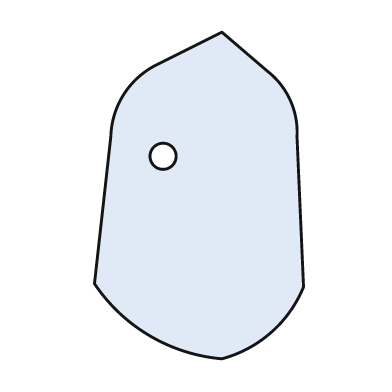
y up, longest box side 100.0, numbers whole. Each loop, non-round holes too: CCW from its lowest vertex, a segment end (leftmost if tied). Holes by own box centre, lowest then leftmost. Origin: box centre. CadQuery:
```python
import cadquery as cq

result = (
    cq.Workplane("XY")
    .moveTo(7.0, -50.0)
    .threePointArc((22.0, -42.0), (32.0, -28.0))
    .lineTo(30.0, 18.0)
    .threePointArc((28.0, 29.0), (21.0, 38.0))
    .lineTo(7.0, 50.0)
    .lineTo(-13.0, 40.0)
    .threePointArc((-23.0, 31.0), (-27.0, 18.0))
    .lineTo(-32.0, -27.0)
    .threePointArc((-15.0, -43.0), (7.0, -50.0))
    .close()
    .moveTo(-11.0, 12.0)
    .circle(4.0)
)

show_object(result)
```